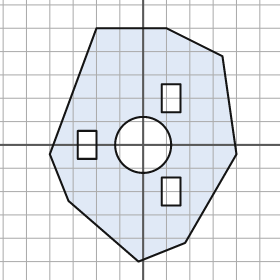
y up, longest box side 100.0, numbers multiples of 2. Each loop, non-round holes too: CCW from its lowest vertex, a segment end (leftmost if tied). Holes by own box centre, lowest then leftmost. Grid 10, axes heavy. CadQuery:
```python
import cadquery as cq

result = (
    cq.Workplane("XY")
    .moveTo(-2.0, -50.0)
    .lineTo(18.0, -42.0)
    .lineTo(40.0, -4.0)
    .lineTo(34.0, 38.0)
    .lineTo(10.0, 50.0)
    .lineTo(-20.0, 50.0)
    .lineTo(-40.0, -4.0)
    .lineTo(-32.0, -24.0)
    .close()
    .moveTo(8.0, -26.0)
    .lineTo(16.0, -26.0)
    .lineTo(16.0, -14.0)
    .lineTo(8.0, -14.0)
    .close()
    .moveTo(-28.0, -6.0)
    .lineTo(-20.0, -6.0)
    .lineTo(-20.0, 6.0)
    .lineTo(-28.0, 6.0)
    .close()
    .moveTo(0.0, 0.0)
    .circle(12.0)
    .moveTo(8.0, 14.0)
    .lineTo(16.0, 14.0)
    .lineTo(16.0, 26.0)
    .lineTo(8.0, 26.0)
    .close()
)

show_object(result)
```